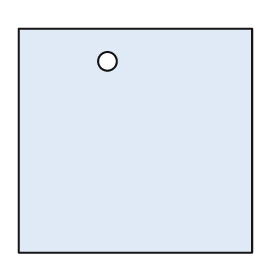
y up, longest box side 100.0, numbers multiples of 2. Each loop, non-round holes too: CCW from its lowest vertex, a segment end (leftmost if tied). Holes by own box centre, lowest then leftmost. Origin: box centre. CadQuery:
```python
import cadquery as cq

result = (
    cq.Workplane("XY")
    .moveTo(-50.0, -48.0)
    .lineTo(50.0, -48.0)
    .lineTo(50.0, 48.0)
    .lineTo(-50.0, 48.0)
    .close()
    .moveTo(-12.0, 34.0)
    .circle(4.0)
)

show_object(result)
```